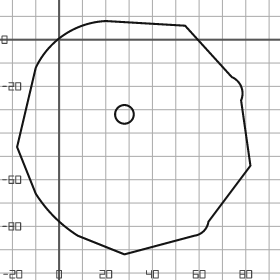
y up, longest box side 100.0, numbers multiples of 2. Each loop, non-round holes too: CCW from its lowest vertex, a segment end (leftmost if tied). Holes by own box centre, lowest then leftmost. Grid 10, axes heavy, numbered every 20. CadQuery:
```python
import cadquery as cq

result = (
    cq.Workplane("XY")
    .moveTo(28.0, -92.0)
    .lineTo(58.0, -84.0)
    .threePointArc((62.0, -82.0), (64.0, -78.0))
    .lineTo(82.0, -54.0)
    .lineTo(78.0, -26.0)
    .threePointArc((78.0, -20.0), (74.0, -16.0))
    .lineTo(54.0, 6.0)
    .lineTo(20.0, 8.0)
    .threePointArc((2.0, 2.0), (-10.0, -12.0))
    .lineTo(-18.0, -46.0)
    .lineTo(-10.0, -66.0)
    .threePointArc((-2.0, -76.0), (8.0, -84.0))
    .close()
    .moveTo(28.0, -32.0)
    .circle(4.0)
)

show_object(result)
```